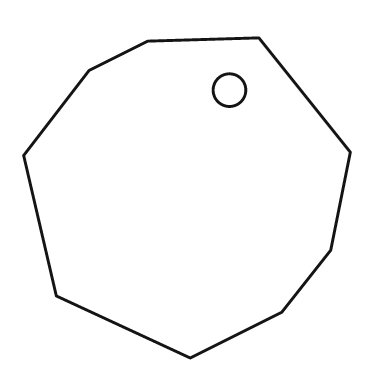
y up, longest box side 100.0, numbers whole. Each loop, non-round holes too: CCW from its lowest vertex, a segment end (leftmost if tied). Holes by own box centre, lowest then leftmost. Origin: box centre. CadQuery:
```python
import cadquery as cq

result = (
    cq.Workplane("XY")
    .moveTo(1.0, -49.0)
    .lineTo(29.0, -35.0)
    .lineTo(44.0, -16.0)
    .lineTo(50.0, 14.0)
    .lineTo(22.0, 49.0)
    .lineTo(-12.0, 48.0)
    .lineTo(-30.0, 39.0)
    .lineTo(-50.0, 13.0)
    .lineTo(-40.0, -30.0)
    .close()
    .moveTo(13.0, 33.0)
    .circle(5.0)
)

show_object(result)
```